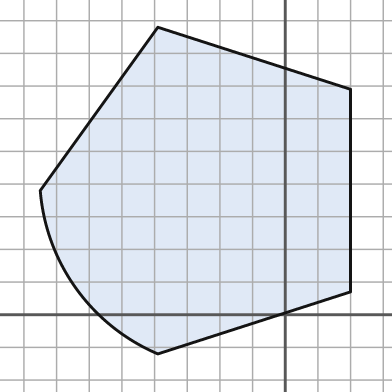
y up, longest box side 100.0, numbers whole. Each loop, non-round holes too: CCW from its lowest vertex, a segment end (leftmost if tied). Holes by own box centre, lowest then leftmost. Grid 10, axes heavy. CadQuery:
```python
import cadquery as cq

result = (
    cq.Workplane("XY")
    .moveTo(-39.0, -12.0)
    .lineTo(20.0, 7.0)
    .lineTo(20.0, 69.0)
    .lineTo(-39.0, 88.0)
    .lineTo(-75.0, 38.0)
    .threePointArc((-64.0, 8.0), (-39.0, -12.0))
    .close()
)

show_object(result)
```